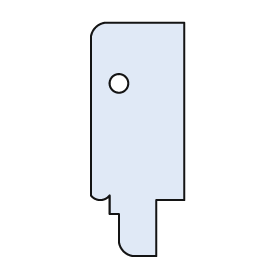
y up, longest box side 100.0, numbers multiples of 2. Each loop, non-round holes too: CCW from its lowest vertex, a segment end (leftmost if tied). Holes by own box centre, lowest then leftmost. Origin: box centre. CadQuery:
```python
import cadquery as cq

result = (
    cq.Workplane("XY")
    .moveTo(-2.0, -50.0)
    .lineTo(8.0, -50.0)
    .lineTo(8.0, -26.0)
    .lineTo(20.0, -26.0)
    .lineTo(20.0, 50.0)
    .lineTo(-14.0, 50.0)
    .threePointArc((-18.0, 48.0), (-20.0, 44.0))
    .lineTo(-20.0, -24.0)
    .threePointArc((-16.0, -26.0), (-12.0, -24.0))
    .lineTo(-12.0, -32.0)
    .lineTo(-8.0, -32.0)
    .lineTo(-8.0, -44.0)
    .threePointArc((-6.0, -48.0), (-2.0, -50.0))
    .close()
    .moveTo(-8.0, 24.0)
    .circle(4.0)
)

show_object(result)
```